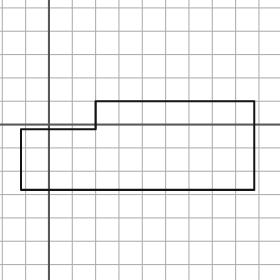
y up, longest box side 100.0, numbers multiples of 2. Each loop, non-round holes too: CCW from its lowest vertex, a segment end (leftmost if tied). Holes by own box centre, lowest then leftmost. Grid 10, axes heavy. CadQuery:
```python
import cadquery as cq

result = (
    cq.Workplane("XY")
    .moveTo(-12.0, -28.0)
    .lineTo(88.0, -28.0)
    .lineTo(88.0, 10.0)
    .lineTo(20.0, 10.0)
    .lineTo(20.0, -2.0)
    .lineTo(-12.0, -2.0)
    .close()
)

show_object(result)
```